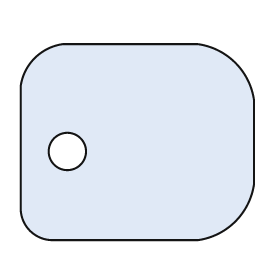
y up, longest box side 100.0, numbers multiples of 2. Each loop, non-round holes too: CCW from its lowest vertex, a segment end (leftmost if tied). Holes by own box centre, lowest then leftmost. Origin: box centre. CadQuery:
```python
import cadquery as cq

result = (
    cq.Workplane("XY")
    .moveTo(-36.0, -42.0)
    .lineTo(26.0, -42.0)
    .threePointArc((42.0, -34.0), (50.0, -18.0))
    .lineTo(50.0, 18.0)
    .threePointArc((42.0, 34.0), (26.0, 42.0))
    .lineTo(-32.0, 42.0)
    .threePointArc((-44.0, 36.0), (-50.0, 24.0))
    .lineTo(-50.0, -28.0)
    .threePointArc((-46.0, -38.0), (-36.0, -42.0))
    .close()
    .moveTo(-30.0, -4.0)
    .circle(8.0)
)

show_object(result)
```